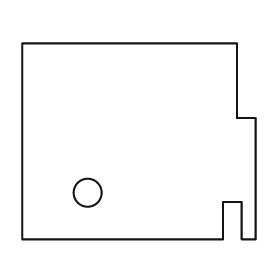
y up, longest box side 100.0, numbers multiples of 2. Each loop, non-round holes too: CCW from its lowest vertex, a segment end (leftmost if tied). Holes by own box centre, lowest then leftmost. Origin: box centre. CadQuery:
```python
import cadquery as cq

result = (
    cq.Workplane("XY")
    .moveTo(-50.0, -42.0)
    .lineTo(36.0, -42.0)
    .lineTo(36.0, -26.0)
    .lineTo(44.0, -26.0)
    .lineTo(44.0, -42.0)
    .lineTo(50.0, -42.0)
    .lineTo(50.0, 10.0)
    .lineTo(42.0, 10.0)
    .lineTo(42.0, 42.0)
    .lineTo(-50.0, 42.0)
    .close()
    .moveTo(-22.0, -22.0)
    .circle(6.0)
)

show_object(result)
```